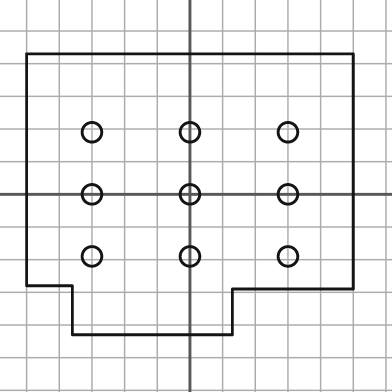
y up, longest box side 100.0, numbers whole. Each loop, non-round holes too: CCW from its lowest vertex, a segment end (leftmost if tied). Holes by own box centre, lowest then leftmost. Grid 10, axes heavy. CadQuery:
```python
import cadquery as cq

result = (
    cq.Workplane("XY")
    .moveTo(-36.0, -43.0)
    .lineTo(13.0, -43.0)
    .lineTo(13.0, -29.0)
    .lineTo(50.0, -29.0)
    .lineTo(50.0, 43.0)
    .lineTo(-50.0, 43.0)
    .lineTo(-50.0, -28.0)
    .lineTo(-36.0, -28.0)
    .close()
    .moveTo(-30.0, -19.0)
    .circle(3.0)
    .moveTo(0.0, -19.0)
    .circle(3.0)
    .moveTo(30.0, -19.0)
    .circle(3.0)
    .moveTo(-30.0, 0.0)
    .circle(3.0)
    .moveTo(0.0, 0.0)
    .circle(3.0)
    .moveTo(30.0, 0.0)
    .circle(3.0)
    .moveTo(-30.0, 19.0)
    .circle(3.0)
    .moveTo(0.0, 19.0)
    .circle(3.0)
    .moveTo(30.0, 19.0)
    .circle(3.0)
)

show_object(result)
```